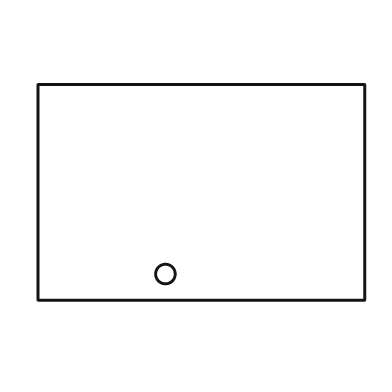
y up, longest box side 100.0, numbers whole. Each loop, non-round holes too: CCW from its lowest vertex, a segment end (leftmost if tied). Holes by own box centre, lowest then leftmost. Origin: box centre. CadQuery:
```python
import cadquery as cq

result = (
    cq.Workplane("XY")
    .moveTo(-50.0, -33.0)
    .lineTo(50.0, -33.0)
    .lineTo(50.0, 33.0)
    .lineTo(-50.0, 33.0)
    .close()
    .moveTo(-11.0, -25.0)
    .circle(3.0)
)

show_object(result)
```